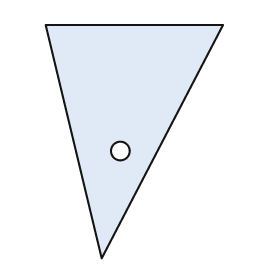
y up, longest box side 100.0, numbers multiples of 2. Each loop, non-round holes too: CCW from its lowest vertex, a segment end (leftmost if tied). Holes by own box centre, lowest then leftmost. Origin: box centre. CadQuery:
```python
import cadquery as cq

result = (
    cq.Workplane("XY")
    .moveTo(-14.0, -50.0)
    .lineTo(38.0, 50.0)
    .lineTo(-38.0, 50.0)
    .close()
    .moveTo(-6.0, -4.0)
    .circle(4.0)
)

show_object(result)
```